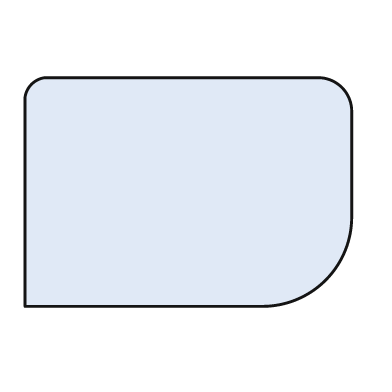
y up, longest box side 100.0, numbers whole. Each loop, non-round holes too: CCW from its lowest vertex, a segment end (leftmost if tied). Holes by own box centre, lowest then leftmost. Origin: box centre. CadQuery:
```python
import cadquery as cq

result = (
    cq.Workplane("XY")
    .moveTo(-50.0, -35.0)
    .lineTo(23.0, -35.0)
    .threePointArc((42.0, -27.0), (50.0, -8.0))
    .lineTo(50.0, 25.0)
    .threePointArc((47.0, 32.0), (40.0, 35.0))
    .lineTo(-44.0, 35.0)
    .threePointArc((-48.0, 33.0), (-50.0, 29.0))
    .close()
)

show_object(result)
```